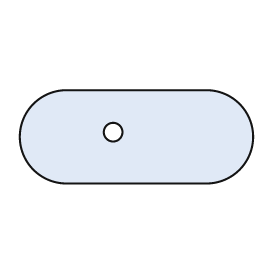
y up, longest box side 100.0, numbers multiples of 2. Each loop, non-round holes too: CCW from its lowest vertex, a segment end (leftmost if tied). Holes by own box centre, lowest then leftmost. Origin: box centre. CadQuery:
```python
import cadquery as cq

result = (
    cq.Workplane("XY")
    .moveTo(-30.0, -20.0)
    .lineTo(30.0, -20.0)
    .threePointArc((50.0, 0.0), (30.0, 20.0))
    .lineTo(-30.0, 20.0)
    .threePointArc((-50.0, 0.0), (-30.0, -20.0))
    .close()
    .moveTo(-10.0, 2.0)
    .circle(4.0)
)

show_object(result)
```